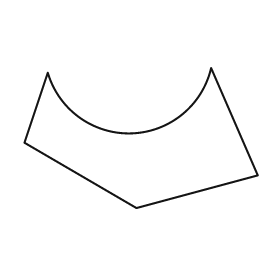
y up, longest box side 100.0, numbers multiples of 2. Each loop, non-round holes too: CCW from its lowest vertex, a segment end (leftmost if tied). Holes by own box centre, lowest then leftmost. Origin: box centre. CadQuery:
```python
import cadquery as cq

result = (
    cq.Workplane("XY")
    .moveTo(-2.0, -30.0)
    .lineTo(50.0, -16.0)
    .lineTo(30.0, 30.0)
    .threePointArc((-4.0, 2.0), (-40.0, 28.0))
    .lineTo(-50.0, -2.0)
    .close()
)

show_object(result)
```